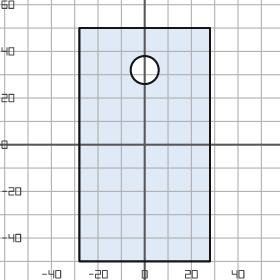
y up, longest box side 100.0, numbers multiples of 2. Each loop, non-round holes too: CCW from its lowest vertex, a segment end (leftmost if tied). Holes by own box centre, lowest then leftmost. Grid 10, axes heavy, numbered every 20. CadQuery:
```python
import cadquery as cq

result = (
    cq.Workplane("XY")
    .moveTo(-28.0, -50.0)
    .lineTo(28.0, -50.0)
    .lineTo(28.0, 50.0)
    .lineTo(-28.0, 50.0)
    .close()
    .moveTo(0.0, 32.0)
    .circle(6.0)
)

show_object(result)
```